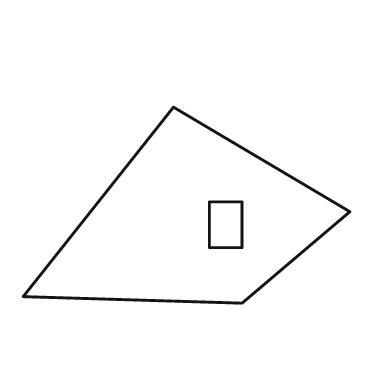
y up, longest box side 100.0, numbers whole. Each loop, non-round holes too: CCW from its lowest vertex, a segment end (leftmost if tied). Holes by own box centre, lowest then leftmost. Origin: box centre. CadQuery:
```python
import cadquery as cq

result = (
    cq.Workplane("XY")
    .moveTo(17.0, -30.0)
    .lineTo(50.0, -2.0)
    .lineTo(-4.0, 30.0)
    .lineTo(-50.0, -28.0)
    .close()
    .moveTo(7.0, -13.0)
    .lineTo(17.0, -13.0)
    .lineTo(17.0, 1.0)
    .lineTo(7.0, 1.0)
    .close()
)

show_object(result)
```